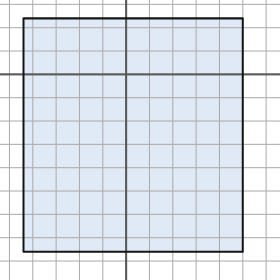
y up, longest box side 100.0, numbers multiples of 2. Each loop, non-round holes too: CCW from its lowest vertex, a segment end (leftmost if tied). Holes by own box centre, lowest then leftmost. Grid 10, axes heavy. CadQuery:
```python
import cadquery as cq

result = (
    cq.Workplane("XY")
    .moveTo(-44.0, -76.0)
    .lineTo(50.0, -76.0)
    .lineTo(50.0, 24.0)
    .lineTo(-44.0, 24.0)
    .close()
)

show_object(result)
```